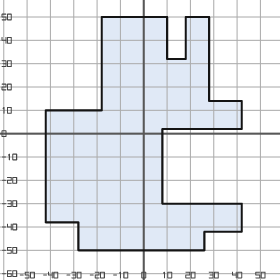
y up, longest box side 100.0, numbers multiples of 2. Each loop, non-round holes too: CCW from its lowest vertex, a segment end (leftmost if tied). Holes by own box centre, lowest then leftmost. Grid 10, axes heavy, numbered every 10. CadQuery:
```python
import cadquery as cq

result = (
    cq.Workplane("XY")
    .moveTo(-28.0, -50.0)
    .lineTo(26.0, -50.0)
    .lineTo(26.0, -42.0)
    .lineTo(42.0, -42.0)
    .lineTo(42.0, -30.0)
    .lineTo(8.0, -30.0)
    .lineTo(8.0, 2.0)
    .lineTo(42.0, 2.0)
    .lineTo(42.0, 14.0)
    .lineTo(28.0, 14.0)
    .lineTo(28.0, 50.0)
    .lineTo(18.0, 50.0)
    .lineTo(18.0, 32.0)
    .lineTo(10.0, 32.0)
    .lineTo(10.0, 50.0)
    .lineTo(-18.0, 50.0)
    .lineTo(-18.0, 10.0)
    .lineTo(-42.0, 10.0)
    .lineTo(-42.0, -38.0)
    .lineTo(-28.0, -38.0)
    .close()
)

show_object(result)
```